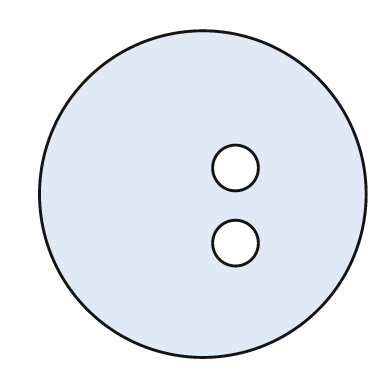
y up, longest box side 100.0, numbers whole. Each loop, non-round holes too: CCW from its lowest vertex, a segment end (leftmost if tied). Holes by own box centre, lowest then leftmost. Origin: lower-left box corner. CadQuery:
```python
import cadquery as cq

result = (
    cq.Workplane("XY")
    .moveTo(50.0, 50.0)
    .circle(50.0)
    .moveTo(60.0, 35.0)
    .circle(7.0)
    .moveTo(60.0, 58.0)
    .circle(7.0)
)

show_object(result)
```